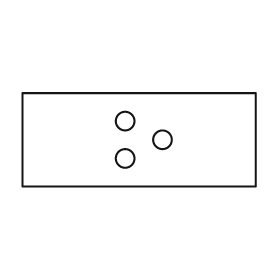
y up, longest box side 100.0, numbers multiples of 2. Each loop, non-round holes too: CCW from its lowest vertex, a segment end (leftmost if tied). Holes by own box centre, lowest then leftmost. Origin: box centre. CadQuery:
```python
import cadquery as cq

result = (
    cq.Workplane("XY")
    .moveTo(-50.0, -20.0)
    .lineTo(50.0, -20.0)
    .lineTo(50.0, 20.0)
    .lineTo(-50.0, 20.0)
    .close()
    .moveTo(-6.0, -8.0)
    .circle(4.0)
    .moveTo(10.0, 0.0)
    .circle(4.0)
    .moveTo(-6.0, 8.0)
    .circle(4.0)
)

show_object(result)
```